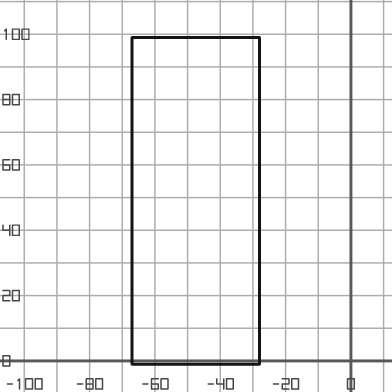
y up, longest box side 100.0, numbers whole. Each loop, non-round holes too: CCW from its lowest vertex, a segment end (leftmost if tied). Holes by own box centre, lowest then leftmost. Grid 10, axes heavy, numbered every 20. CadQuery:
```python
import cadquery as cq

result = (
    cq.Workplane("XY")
    .moveTo(-67.0, -1.0)
    .lineTo(-28.0, -1.0)
    .lineTo(-28.0, 99.0)
    .lineTo(-67.0, 99.0)
    .close()
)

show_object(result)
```